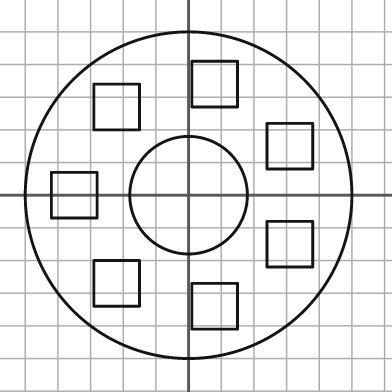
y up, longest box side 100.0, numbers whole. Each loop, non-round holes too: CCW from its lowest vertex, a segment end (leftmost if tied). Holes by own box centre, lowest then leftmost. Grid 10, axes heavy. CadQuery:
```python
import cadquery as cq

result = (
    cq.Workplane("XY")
    .moveTo(0.0, 0.0)
    .circle(50.0)
    .moveTo(1.0, -41.0)
    .lineTo(15.0, -41.0)
    .lineTo(15.0, -27.0)
    .lineTo(1.0, -27.0)
    .close()
    .moveTo(-29.0, -34.0)
    .lineTo(-15.0, -34.0)
    .lineTo(-15.0, -20.0)
    .lineTo(-29.0, -20.0)
    .close()
    .moveTo(24.0, -22.0)
    .lineTo(38.0, -22.0)
    .lineTo(38.0, -8.0)
    .lineTo(24.0, -8.0)
    .close()
    .moveTo(-42.0, -7.0)
    .lineTo(-28.0, -7.0)
    .lineTo(-28.0, 7.0)
    .lineTo(-42.0, 7.0)
    .close()
    .moveTo(0.0, 0.0)
    .circle(18.0)
    .moveTo(24.0, 8.0)
    .lineTo(38.0, 8.0)
    .lineTo(38.0, 22.0)
    .lineTo(24.0, 22.0)
    .close()
    .moveTo(-29.0, 20.0)
    .lineTo(-15.0, 20.0)
    .lineTo(-15.0, 34.0)
    .lineTo(-29.0, 34.0)
    .close()
    .moveTo(1.0, 27.0)
    .lineTo(15.0, 27.0)
    .lineTo(15.0, 41.0)
    .lineTo(1.0, 41.0)
    .close()
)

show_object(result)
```